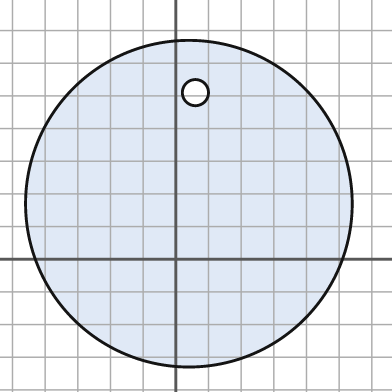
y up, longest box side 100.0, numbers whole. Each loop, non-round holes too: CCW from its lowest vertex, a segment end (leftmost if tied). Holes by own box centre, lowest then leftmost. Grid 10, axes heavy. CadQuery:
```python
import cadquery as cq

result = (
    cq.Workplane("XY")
    .moveTo(4.0, 17.0)
    .circle(50.0)
    .moveTo(6.0, 51.0)
    .circle(4.0)
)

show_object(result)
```